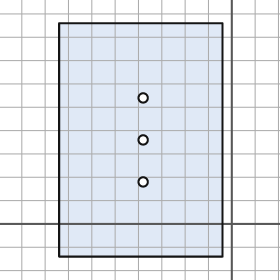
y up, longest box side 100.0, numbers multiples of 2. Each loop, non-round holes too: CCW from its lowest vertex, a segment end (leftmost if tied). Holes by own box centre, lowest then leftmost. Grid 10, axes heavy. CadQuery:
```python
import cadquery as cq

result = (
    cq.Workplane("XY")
    .moveTo(-74.0, -14.0)
    .lineTo(-4.0, -14.0)
    .lineTo(-4.0, 86.0)
    .lineTo(-74.0, 86.0)
    .close()
    .moveTo(-38.0, 18.0)
    .circle(2.0)
    .moveTo(-38.0, 36.0)
    .circle(2.0)
    .moveTo(-38.0, 54.0)
    .circle(2.0)
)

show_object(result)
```